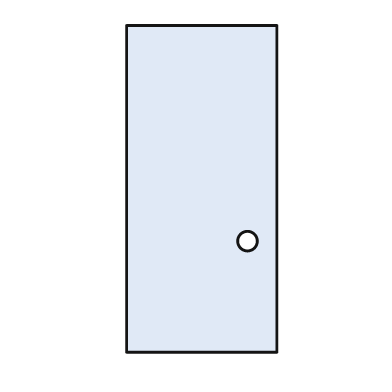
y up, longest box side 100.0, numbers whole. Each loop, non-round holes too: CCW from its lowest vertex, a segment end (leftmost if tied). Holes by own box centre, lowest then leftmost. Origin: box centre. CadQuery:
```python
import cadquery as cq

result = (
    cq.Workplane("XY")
    .moveTo(-23.0, -50.0)
    .lineTo(23.0, -50.0)
    .lineTo(23.0, 50.0)
    .lineTo(-23.0, 50.0)
    .close()
    .moveTo(14.0, -16.0)
    .circle(3.0)
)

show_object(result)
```